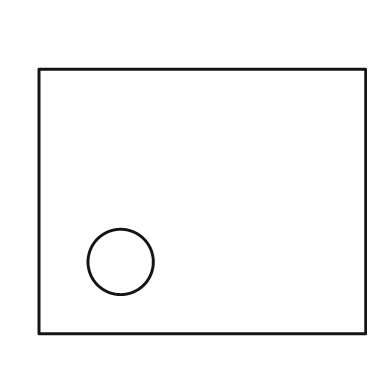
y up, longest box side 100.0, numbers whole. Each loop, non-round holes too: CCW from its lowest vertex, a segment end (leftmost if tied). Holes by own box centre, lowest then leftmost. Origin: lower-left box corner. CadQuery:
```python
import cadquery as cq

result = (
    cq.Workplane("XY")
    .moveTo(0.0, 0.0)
    .lineTo(100.0, 0.0)
    .lineTo(100.0, 81.0)
    .lineTo(0.0, 81.0)
    .close()
    .moveTo(25.0, 22.0)
    .circle(10.0)
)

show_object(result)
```